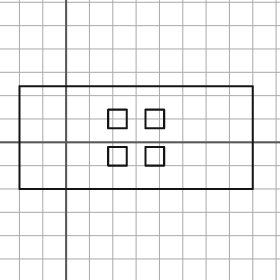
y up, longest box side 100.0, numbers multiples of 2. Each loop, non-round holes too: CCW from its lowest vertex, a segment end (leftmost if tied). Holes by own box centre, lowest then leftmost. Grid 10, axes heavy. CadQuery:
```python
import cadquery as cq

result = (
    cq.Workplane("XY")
    .moveTo(-20.0, -20.0)
    .lineTo(80.0, -20.0)
    .lineTo(80.0, 24.0)
    .lineTo(-20.0, 24.0)
    .close()
    .moveTo(18.0, -10.0)
    .lineTo(26.0, -10.0)
    .lineTo(26.0, -2.0)
    .lineTo(18.0, -2.0)
    .close()
    .moveTo(34.0, -10.0)
    .lineTo(42.0, -10.0)
    .lineTo(42.0, -2.0)
    .lineTo(34.0, -2.0)
    .close()
    .moveTo(18.0, 6.0)
    .lineTo(26.0, 6.0)
    .lineTo(26.0, 14.0)
    .lineTo(18.0, 14.0)
    .close()
    .moveTo(34.0, 6.0)
    .lineTo(42.0, 6.0)
    .lineTo(42.0, 14.0)
    .lineTo(34.0, 14.0)
    .close()
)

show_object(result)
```